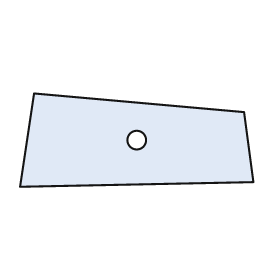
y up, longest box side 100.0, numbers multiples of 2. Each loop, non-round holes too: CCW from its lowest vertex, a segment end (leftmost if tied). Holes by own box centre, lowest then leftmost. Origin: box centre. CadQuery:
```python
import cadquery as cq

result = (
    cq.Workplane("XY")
    .moveTo(-50.0, -20.0)
    .lineTo(50.0, -18.0)
    .lineTo(46.0, 12.0)
    .lineTo(-44.0, 20.0)
    .close()
    .moveTo(0.0, 0.0)
    .circle(4.0)
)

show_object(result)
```